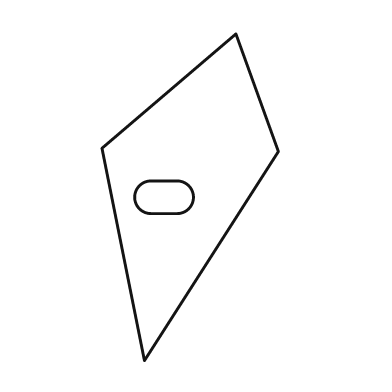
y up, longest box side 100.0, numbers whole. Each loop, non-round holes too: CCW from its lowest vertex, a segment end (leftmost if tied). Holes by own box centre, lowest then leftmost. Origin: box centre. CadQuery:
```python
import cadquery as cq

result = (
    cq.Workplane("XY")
    .moveTo(-14.0, -50.0)
    .lineTo(27.0, 14.0)
    .lineTo(14.0, 50.0)
    .lineTo(-27.0, 15.0)
    .close()
    .moveTo(-12.0, -5.0)
    .lineTo(-4.0, -5.0)
    .threePointArc((1.0, 0.0), (-4.0, 5.0))
    .lineTo(-12.0, 5.0)
    .threePointArc((-17.0, 0.0), (-12.0, -5.0))
    .close()
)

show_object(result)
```